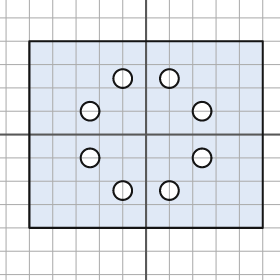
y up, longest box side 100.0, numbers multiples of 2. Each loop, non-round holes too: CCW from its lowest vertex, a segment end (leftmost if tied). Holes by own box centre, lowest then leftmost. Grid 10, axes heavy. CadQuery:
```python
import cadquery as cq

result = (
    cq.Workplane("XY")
    .moveTo(-50.0, -40.0)
    .lineTo(50.0, -40.0)
    .lineTo(50.0, 40.0)
    .lineTo(-50.0, 40.0)
    .close()
    .moveTo(-10.0, -24.0)
    .circle(4.0)
    .moveTo(10.0, -24.0)
    .circle(4.0)
    .moveTo(-24.0, -10.0)
    .circle(4.0)
    .moveTo(24.0, -10.0)
    .circle(4.0)
    .moveTo(-24.0, 10.0)
    .circle(4.0)
    .moveTo(24.0, 10.0)
    .circle(4.0)
    .moveTo(-10.0, 24.0)
    .circle(4.0)
    .moveTo(10.0, 24.0)
    .circle(4.0)
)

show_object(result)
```